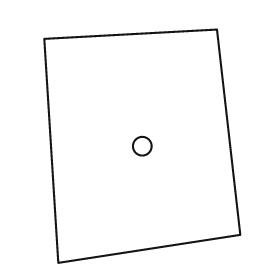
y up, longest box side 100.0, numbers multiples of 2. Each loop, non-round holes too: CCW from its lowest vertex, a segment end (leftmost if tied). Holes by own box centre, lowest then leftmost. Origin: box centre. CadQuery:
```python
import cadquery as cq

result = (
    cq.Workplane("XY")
    .moveTo(-36.0, -50.0)
    .lineTo(42.0, -38.0)
    .lineTo(32.0, 50.0)
    .lineTo(-42.0, 46.0)
    .close()
    .moveTo(0.0, 0.0)
    .circle(4.0)
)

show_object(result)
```